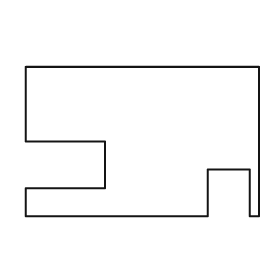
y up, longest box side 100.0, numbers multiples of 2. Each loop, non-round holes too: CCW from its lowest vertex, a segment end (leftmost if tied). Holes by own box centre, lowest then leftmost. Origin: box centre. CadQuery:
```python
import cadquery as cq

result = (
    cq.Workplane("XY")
    .moveTo(-50.0, -32.0)
    .lineTo(28.0, -32.0)
    .lineTo(28.0, -12.0)
    .lineTo(46.0, -12.0)
    .lineTo(46.0, -32.0)
    .lineTo(50.0, -32.0)
    .lineTo(50.0, 32.0)
    .lineTo(-50.0, 32.0)
    .lineTo(-50.0, 0.0)
    .lineTo(-16.0, 0.0)
    .lineTo(-16.0, -20.0)
    .lineTo(-50.0, -20.0)
    .close()
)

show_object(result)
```